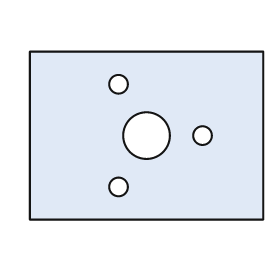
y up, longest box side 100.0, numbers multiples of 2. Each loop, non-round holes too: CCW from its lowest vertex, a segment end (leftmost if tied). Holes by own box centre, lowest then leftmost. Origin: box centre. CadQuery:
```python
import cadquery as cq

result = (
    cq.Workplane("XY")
    .moveTo(-50.0, -36.0)
    .lineTo(50.0, -36.0)
    .lineTo(50.0, 36.0)
    .lineTo(-50.0, 36.0)
    .close()
    .moveTo(-12.0, -22.0)
    .circle(4.0)
    .moveTo(0.0, 0.0)
    .circle(10.0)
    .moveTo(24.0, 0.0)
    .circle(4.0)
    .moveTo(-12.0, 22.0)
    .circle(4.0)
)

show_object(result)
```